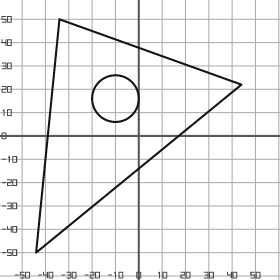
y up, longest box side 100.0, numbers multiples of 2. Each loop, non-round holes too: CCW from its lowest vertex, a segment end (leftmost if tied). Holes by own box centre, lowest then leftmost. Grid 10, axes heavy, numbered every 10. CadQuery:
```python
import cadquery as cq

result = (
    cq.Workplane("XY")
    .moveTo(-44.0, -50.0)
    .lineTo(44.0, 22.0)
    .lineTo(-34.0, 50.0)
    .close()
    .moveTo(-10.0, 16.0)
    .circle(10.0)
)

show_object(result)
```